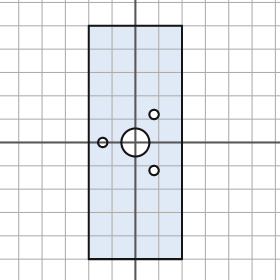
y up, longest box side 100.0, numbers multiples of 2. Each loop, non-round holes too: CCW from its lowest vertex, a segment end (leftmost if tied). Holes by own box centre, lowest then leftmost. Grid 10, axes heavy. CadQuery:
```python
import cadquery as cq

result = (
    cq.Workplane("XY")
    .moveTo(-20.0, -50.0)
    .lineTo(20.0, -50.0)
    .lineTo(20.0, 50.0)
    .lineTo(-20.0, 50.0)
    .close()
    .moveTo(8.0, -12.0)
    .circle(2.0)
    .moveTo(-14.0, 0.0)
    .circle(2.0)
    .moveTo(0.0, 0.0)
    .circle(6.0)
    .moveTo(8.0, 12.0)
    .circle(2.0)
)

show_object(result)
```